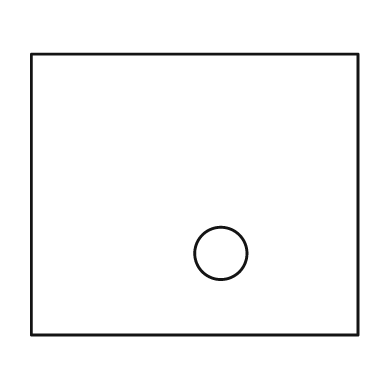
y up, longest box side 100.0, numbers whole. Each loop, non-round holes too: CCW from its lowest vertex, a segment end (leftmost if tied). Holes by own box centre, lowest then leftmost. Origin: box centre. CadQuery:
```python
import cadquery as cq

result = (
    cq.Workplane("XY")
    .moveTo(-50.0, -43.0)
    .lineTo(50.0, -43.0)
    .lineTo(50.0, 43.0)
    .lineTo(-50.0, 43.0)
    .close()
    .moveTo(8.0, -18.0)
    .circle(8.0)
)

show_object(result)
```